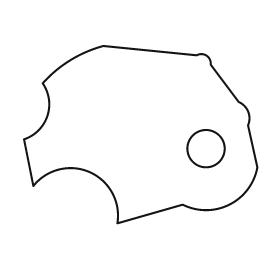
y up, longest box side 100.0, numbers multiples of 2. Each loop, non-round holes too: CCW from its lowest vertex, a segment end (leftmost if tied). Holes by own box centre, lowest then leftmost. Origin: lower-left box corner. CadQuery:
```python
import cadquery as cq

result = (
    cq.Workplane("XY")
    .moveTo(40.0, 0.0)
    .lineTo(68.0, 8.0)
    .threePointArc((88.0, 8.0), (100.0, 24.0))
    .lineTo(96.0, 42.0)
    .threePointArc((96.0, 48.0), (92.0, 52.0))
    .lineTo(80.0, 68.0)
    .threePointArc((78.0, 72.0), (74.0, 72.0))
    .lineTo(34.0, 76.0)
    .threePointArc((20.0, 70.0), (8.0, 60.0))
    .threePointArc((10.0, 46.0), (0.0, 36.0))
    .lineTo(4.0, 16.0)
    .threePointArc((28.0, 22.0), (40.0, 0.0))
    .close()
    .moveTo(78.0, 32.0)
    .circle(8.0)
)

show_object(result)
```